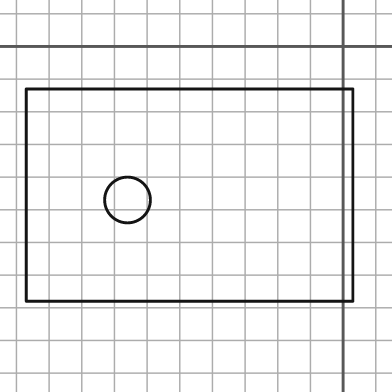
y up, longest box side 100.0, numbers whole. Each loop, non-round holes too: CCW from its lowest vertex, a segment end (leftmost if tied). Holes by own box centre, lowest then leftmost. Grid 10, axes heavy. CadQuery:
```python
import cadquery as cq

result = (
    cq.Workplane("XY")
    .moveTo(-97.0, -78.0)
    .lineTo(3.0, -78.0)
    .lineTo(3.0, -13.0)
    .lineTo(-97.0, -13.0)
    .close()
    .moveTo(-66.0, -47.0)
    .circle(7.0)
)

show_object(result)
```